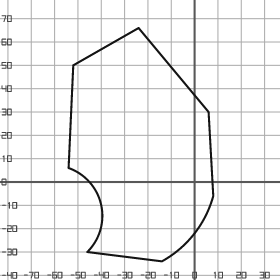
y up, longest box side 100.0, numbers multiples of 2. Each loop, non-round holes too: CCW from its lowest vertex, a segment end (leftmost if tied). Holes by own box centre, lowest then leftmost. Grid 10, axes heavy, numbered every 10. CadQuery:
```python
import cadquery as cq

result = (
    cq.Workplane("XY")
    .moveTo(-14.0, -34.0)
    .threePointArc((0.0, -22.0), (8.0, -6.0))
    .lineTo(6.0, 30.0)
    .lineTo(-24.0, 66.0)
    .lineTo(-52.0, 50.0)
    .lineTo(-54.0, 6.0)
    .threePointArc((-40.0, -10.0), (-46.0, -30.0))
    .close()
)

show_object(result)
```